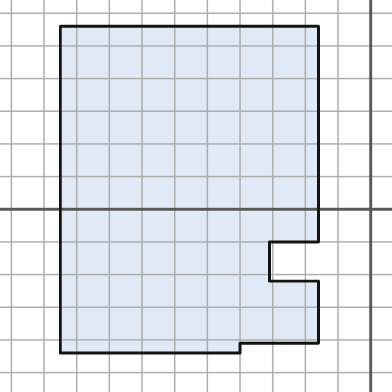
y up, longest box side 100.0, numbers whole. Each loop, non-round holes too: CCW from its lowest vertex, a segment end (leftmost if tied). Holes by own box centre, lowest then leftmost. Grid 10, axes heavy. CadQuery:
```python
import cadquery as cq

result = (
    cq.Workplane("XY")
    .moveTo(-95.0, -44.0)
    .lineTo(-40.0, -44.0)
    .lineTo(-40.0, -41.0)
    .lineTo(-16.0, -41.0)
    .lineTo(-16.0, -22.0)
    .lineTo(-31.0, -22.0)
    .lineTo(-31.0, -10.0)
    .lineTo(-16.0, -10.0)
    .lineTo(-16.0, 56.0)
    .lineTo(-95.0, 56.0)
    .close()
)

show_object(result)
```